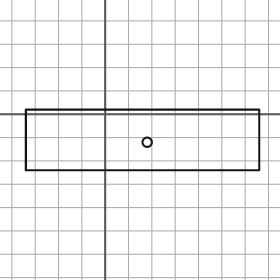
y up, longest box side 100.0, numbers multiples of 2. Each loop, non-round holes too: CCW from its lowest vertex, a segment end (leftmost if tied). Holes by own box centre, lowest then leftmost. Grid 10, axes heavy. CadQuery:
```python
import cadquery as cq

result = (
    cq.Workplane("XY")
    .moveTo(-34.0, -24.0)
    .lineTo(66.0, -24.0)
    .lineTo(66.0, 2.0)
    .lineTo(-34.0, 2.0)
    .close()
    .moveTo(18.0, -12.0)
    .circle(2.0)
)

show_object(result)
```